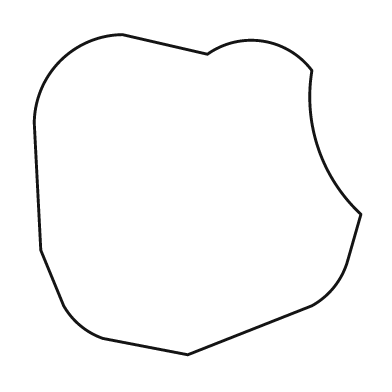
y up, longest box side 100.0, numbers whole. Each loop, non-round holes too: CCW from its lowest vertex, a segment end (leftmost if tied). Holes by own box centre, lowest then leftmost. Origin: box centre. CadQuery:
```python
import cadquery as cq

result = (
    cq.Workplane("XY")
    .moveTo(-3.0, -49.0)
    .lineTo(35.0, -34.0)
    .threePointArc((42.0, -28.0), (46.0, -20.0))
    .lineTo(50.0, -6.0)
    .threePointArc((37.0, 14.0), (35.0, 38.0))
    .threePointArc((20.0, 47.0), (3.0, 43.0))
    .lineTo(-23.0, 49.0)
    .threePointArc((-42.0, 41.0), (-50.0, 22.0))
    .lineTo(-48.0, -17.0)
    .lineTo(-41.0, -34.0)
    .threePointArc((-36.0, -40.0), (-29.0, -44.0))
    .close()
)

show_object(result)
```